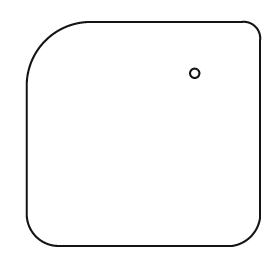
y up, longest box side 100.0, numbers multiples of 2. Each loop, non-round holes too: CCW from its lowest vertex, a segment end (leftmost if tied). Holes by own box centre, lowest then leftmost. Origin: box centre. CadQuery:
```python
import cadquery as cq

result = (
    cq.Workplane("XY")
    .moveTo(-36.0, -48.0)
    .lineTo(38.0, -48.0)
    .threePointArc((46.0, -44.0), (50.0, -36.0))
    .lineTo(50.0, 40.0)
    .threePointArc((48.0, 46.0), (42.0, 48.0))
    .lineTo(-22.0, 48.0)
    .threePointArc((-42.0, 40.0), (-50.0, 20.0))
    .lineTo(-50.0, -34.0)
    .threePointArc((-46.0, -44.0), (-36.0, -48.0))
    .close()
    .moveTo(22.0, 26.0)
    .circle(2.0)
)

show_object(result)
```